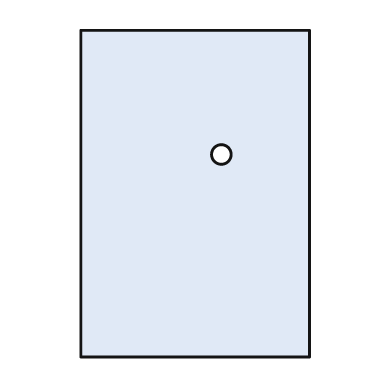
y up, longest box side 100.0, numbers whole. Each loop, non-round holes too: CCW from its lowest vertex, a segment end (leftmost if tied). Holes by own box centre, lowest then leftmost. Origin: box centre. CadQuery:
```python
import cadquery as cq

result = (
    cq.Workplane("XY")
    .moveTo(-35.0, -50.0)
    .lineTo(35.0, -50.0)
    .lineTo(35.0, 50.0)
    .lineTo(-35.0, 50.0)
    .close()
    .moveTo(8.0, 12.0)
    .circle(3.0)
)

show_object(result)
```